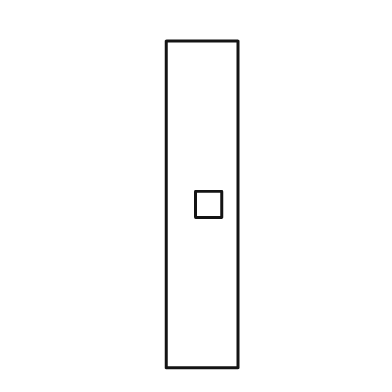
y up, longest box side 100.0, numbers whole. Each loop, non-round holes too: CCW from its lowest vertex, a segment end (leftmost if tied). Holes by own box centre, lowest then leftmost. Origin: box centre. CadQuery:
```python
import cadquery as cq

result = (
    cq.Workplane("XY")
    .moveTo(-11.0, -50.0)
    .lineTo(11.0, -50.0)
    .lineTo(11.0, 50.0)
    .lineTo(-11.0, 50.0)
    .close()
    .moveTo(-2.0, -4.0)
    .lineTo(6.0, -4.0)
    .lineTo(6.0, 4.0)
    .lineTo(-2.0, 4.0)
    .close()
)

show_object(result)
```